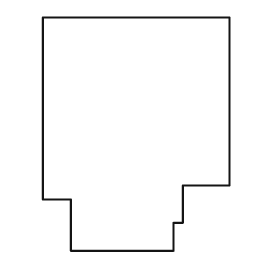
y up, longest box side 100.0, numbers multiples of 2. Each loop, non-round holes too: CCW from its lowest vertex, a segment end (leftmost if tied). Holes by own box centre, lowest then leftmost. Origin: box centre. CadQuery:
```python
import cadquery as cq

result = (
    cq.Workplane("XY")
    .moveTo(-28.0, -50.0)
    .lineTo(16.0, -50.0)
    .lineTo(16.0, -38.0)
    .lineTo(20.0, -38.0)
    .lineTo(20.0, -22.0)
    .lineTo(40.0, -22.0)
    .lineTo(40.0, 50.0)
    .lineTo(-40.0, 50.0)
    .lineTo(-40.0, -28.0)
    .lineTo(-28.0, -28.0)
    .close()
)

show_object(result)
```